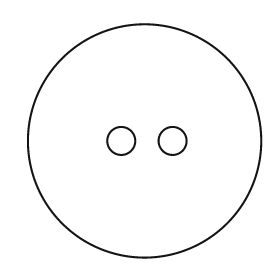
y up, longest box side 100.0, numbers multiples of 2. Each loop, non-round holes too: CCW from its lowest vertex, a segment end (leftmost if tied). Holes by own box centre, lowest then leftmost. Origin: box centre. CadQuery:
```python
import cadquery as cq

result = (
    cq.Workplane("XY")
    .moveTo(0.0, 0.0)
    .circle(50.0)
    .moveTo(-10.0, 0.0)
    .circle(6.0)
    .moveTo(12.0, 0.0)
    .circle(6.0)
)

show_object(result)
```